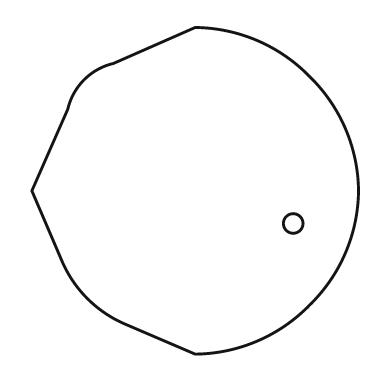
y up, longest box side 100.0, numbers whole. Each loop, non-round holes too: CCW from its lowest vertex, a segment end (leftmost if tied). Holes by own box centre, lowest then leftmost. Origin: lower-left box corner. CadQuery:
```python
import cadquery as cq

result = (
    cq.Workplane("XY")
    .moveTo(50.0, 0.0)
    .threePointArc((69.0, 4.0), (85.0, 15.0))
    .threePointArc((96.0, 31.0), (100.0, 50.0))
    .threePointArc((96.0, 69.0), (85.0, 85.0))
    .threePointArc((69.0, 96.0), (50.0, 100.0))
    .lineTo(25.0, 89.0)
    .threePointArc((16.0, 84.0), (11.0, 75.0))
    .lineTo(0.0, 50.0)
    .lineTo(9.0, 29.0)
    .threePointArc((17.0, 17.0), (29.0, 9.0))
    .close()
    .moveTo(80.0, 40.0)
    .circle(3.0)
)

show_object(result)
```